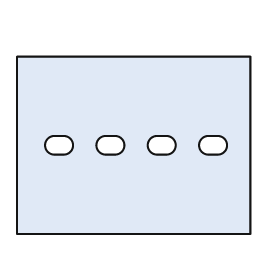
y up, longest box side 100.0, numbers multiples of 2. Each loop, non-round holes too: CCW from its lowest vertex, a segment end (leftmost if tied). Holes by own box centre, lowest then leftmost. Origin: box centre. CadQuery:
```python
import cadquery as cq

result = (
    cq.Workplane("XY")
    .moveTo(-50.0, -38.0)
    .lineTo(50.0, -38.0)
    .lineTo(50.0, 38.0)
    .lineTo(-50.0, 38.0)
    .close()
    .moveTo(-34.0, -4.0)
    .lineTo(-30.0, -4.0)
    .threePointArc((-26.0, 0.0), (-30.0, 4.0))
    .lineTo(-34.0, 4.0)
    .threePointArc((-38.0, 0.0), (-34.0, -4.0))
    .close()
    .moveTo(-12.0, -4.0)
    .lineTo(-8.0, -4.0)
    .threePointArc((-4.0, 0.0), (-8.0, 4.0))
    .lineTo(-12.0, 4.0)
    .threePointArc((-16.0, 0.0), (-12.0, -4.0))
    .close()
    .moveTo(10.0, -4.0)
    .lineTo(14.0, -4.0)
    .threePointArc((18.0, 0.0), (14.0, 4.0))
    .lineTo(10.0, 4.0)
    .threePointArc((6.0, 0.0), (10.0, -4.0))
    .close()
    .moveTo(32.0, -4.0)
    .lineTo(36.0, -4.0)
    .threePointArc((40.0, 0.0), (36.0, 4.0))
    .lineTo(32.0, 4.0)
    .threePointArc((28.0, 0.0), (32.0, -4.0))
    .close()
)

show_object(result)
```